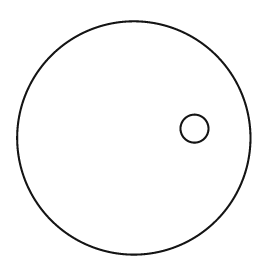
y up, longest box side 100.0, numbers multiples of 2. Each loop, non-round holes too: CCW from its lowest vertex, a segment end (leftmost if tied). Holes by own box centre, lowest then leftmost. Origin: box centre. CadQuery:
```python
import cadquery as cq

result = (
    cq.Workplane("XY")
    .moveTo(0.0, 0.0)
    .circle(50.0)
    .moveTo(26.0, 4.0)
    .circle(6.0)
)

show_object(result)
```